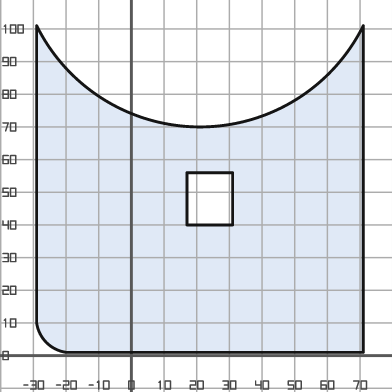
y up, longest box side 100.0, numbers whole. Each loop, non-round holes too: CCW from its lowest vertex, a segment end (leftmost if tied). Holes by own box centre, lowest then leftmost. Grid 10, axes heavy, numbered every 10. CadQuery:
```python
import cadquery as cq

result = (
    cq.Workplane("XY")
    .moveTo(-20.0, 1.0)
    .lineTo(71.0, 1.0)
    .lineTo(71.0, 101.0)
    .threePointArc((21.0, 70.0), (-29.0, 101.0))
    .lineTo(-29.0, 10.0)
    .threePointArc((-26.0, 4.0), (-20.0, 1.0))
    .close()
    .moveTo(17.0, 40.0)
    .lineTo(31.0, 40.0)
    .lineTo(31.0, 56.0)
    .lineTo(17.0, 56.0)
    .close()
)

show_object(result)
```